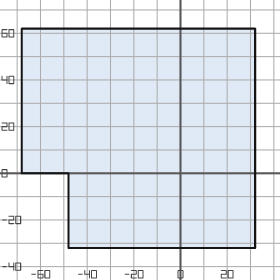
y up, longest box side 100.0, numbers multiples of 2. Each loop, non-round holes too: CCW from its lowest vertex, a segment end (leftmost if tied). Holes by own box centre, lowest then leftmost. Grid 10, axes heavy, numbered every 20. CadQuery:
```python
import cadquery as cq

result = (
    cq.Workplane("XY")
    .moveTo(-48.0, -32.0)
    .lineTo(32.0, -32.0)
    .lineTo(32.0, 62.0)
    .lineTo(-68.0, 62.0)
    .lineTo(-68.0, 0.0)
    .lineTo(-48.0, 0.0)
    .close()
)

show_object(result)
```